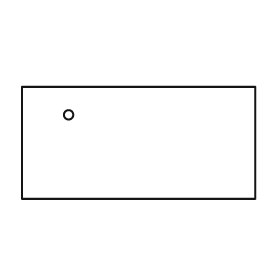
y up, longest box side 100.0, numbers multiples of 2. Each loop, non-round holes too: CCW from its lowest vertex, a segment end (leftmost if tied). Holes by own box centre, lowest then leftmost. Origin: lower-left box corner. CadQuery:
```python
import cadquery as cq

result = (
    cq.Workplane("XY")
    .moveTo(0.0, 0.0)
    .lineTo(100.0, 0.0)
    .lineTo(100.0, 48.0)
    .lineTo(0.0, 48.0)
    .close()
    .moveTo(20.0, 36.0)
    .circle(2.0)
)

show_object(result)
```